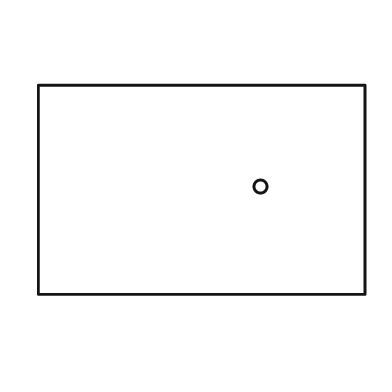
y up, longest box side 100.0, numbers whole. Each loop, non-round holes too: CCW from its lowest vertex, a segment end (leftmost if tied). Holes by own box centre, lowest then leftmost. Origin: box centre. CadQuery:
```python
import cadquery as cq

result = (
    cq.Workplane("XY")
    .moveTo(-50.0, -32.0)
    .lineTo(50.0, -32.0)
    .lineTo(50.0, 32.0)
    .lineTo(-50.0, 32.0)
    .close()
    .moveTo(18.0, 1.0)
    .circle(2.0)
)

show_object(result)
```